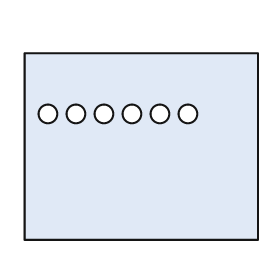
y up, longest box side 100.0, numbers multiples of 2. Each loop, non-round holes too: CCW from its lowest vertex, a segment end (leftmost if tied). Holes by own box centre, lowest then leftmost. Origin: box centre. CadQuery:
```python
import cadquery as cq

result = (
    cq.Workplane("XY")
    .moveTo(-50.0, -40.0)
    .lineTo(50.0, -40.0)
    .lineTo(50.0, 40.0)
    .lineTo(-50.0, 40.0)
    .close()
    .moveTo(-40.0, 14.0)
    .circle(4.0)
    .moveTo(-28.0, 14.0)
    .circle(4.0)
    .moveTo(-16.0, 14.0)
    .circle(4.0)
    .moveTo(-4.0, 14.0)
    .circle(4.0)
    .moveTo(8.0, 14.0)
    .circle(4.0)
    .moveTo(20.0, 14.0)
    .circle(4.0)
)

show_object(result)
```